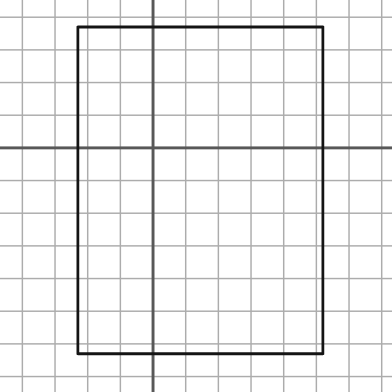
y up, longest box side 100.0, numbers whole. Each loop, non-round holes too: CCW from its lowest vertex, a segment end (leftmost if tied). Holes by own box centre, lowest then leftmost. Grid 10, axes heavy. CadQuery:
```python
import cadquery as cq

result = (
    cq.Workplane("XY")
    .moveTo(-23.0, -63.0)
    .lineTo(52.0, -63.0)
    .lineTo(52.0, 37.0)
    .lineTo(-23.0, 37.0)
    .close()
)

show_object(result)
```